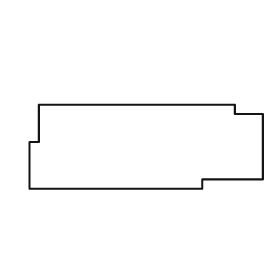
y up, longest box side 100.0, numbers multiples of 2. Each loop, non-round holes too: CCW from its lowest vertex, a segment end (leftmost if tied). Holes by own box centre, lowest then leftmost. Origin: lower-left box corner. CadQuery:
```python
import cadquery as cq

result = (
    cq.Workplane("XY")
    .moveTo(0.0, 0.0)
    .lineTo(74.0, 0.0)
    .lineTo(74.0, 4.0)
    .lineTo(100.0, 4.0)
    .lineTo(100.0, 32.0)
    .lineTo(88.0, 32.0)
    .lineTo(88.0, 36.0)
    .lineTo(4.0, 36.0)
    .lineTo(4.0, 20.0)
    .lineTo(0.0, 20.0)
    .close()
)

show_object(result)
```